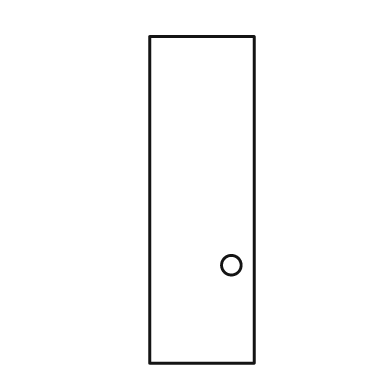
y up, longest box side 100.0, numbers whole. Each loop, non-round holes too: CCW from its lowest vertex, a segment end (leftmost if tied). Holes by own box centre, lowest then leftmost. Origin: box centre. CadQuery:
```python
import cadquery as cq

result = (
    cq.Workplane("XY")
    .moveTo(-16.0, -50.0)
    .lineTo(16.0, -50.0)
    .lineTo(16.0, 50.0)
    .lineTo(-16.0, 50.0)
    .close()
    .moveTo(9.0, -20.0)
    .circle(3.0)
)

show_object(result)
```